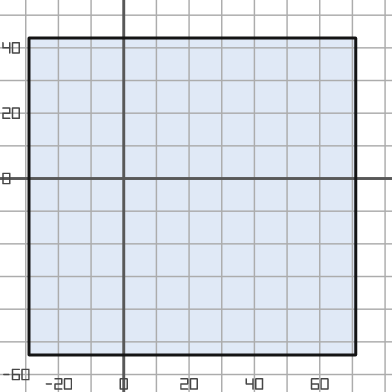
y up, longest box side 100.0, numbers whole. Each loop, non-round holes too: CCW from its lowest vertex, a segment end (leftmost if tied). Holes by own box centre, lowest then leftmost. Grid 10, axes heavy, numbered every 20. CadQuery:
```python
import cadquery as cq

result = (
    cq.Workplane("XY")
    .moveTo(-29.0, -54.0)
    .lineTo(71.0, -54.0)
    .lineTo(71.0, 43.0)
    .lineTo(-29.0, 43.0)
    .close()
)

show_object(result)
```